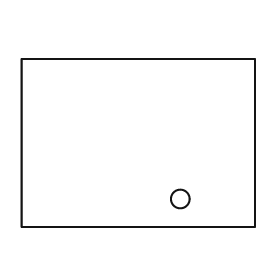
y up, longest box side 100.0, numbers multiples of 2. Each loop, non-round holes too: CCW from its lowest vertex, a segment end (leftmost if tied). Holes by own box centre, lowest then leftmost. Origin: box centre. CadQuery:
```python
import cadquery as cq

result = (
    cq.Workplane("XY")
    .moveTo(-50.0, -36.0)
    .lineTo(50.0, -36.0)
    .lineTo(50.0, 36.0)
    .lineTo(-50.0, 36.0)
    .close()
    .moveTo(18.0, -24.0)
    .circle(4.0)
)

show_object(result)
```